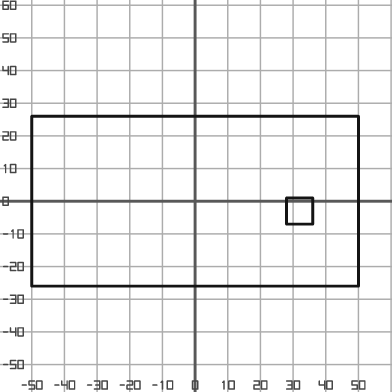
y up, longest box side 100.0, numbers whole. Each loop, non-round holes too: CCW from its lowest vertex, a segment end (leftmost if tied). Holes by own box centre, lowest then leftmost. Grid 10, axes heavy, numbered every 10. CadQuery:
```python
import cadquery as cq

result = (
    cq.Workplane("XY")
    .moveTo(-50.0, -26.0)
    .lineTo(50.0, -26.0)
    .lineTo(50.0, 26.0)
    .lineTo(-50.0, 26.0)
    .close()
    .moveTo(28.0, -7.0)
    .lineTo(36.0, -7.0)
    .lineTo(36.0, 1.0)
    .lineTo(28.0, 1.0)
    .close()
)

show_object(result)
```